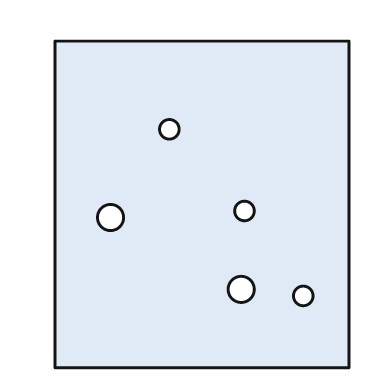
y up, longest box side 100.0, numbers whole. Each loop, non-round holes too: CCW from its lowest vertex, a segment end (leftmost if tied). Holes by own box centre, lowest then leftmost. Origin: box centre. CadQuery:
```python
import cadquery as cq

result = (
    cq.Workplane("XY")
    .moveTo(-45.0, -50.0)
    .lineTo(45.0, -50.0)
    .lineTo(45.0, 50.0)
    .lineTo(-45.0, 50.0)
    .close()
    .moveTo(31.0, -28.0)
    .circle(3.0)
    .moveTo(12.0, -26.0)
    .circle(4.0)
    .moveTo(-28.0, -4.0)
    .circle(4.0)
    .moveTo(13.0, -2.0)
    .circle(3.0)
    .moveTo(-10.0, 23.0)
    .circle(3.0)
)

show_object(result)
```